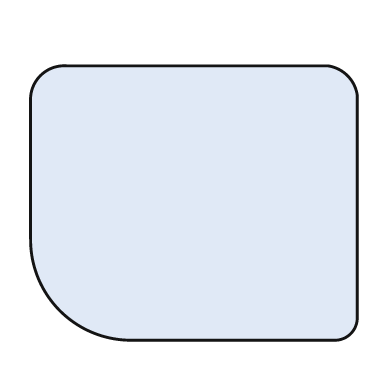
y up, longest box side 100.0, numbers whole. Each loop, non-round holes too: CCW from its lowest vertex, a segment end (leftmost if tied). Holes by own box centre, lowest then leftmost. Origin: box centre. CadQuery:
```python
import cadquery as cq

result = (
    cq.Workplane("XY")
    .moveTo(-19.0, -42.0)
    .lineTo(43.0, -42.0)
    .threePointArc((48.0, -40.0), (50.0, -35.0))
    .lineTo(50.0, 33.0)
    .threePointArc((47.0, 39.0), (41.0, 42.0))
    .lineTo(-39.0, 42.0)
    .threePointArc((-47.0, 39.0), (-50.0, 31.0))
    .lineTo(-50.0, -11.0)
    .threePointArc((-41.0, -33.0), (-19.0, -42.0))
    .close()
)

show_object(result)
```